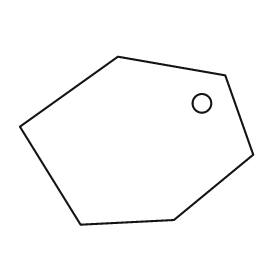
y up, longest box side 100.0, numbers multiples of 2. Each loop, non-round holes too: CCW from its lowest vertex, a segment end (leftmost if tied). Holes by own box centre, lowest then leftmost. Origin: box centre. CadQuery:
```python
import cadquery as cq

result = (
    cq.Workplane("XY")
    .moveTo(-24.0, -36.0)
    .lineTo(16.0, -34.0)
    .lineTo(50.0, -6.0)
    .lineTo(38.0, 28.0)
    .lineTo(-8.0, 36.0)
    .lineTo(-50.0, 6.0)
    .close()
    .moveTo(28.0, 16.0)
    .circle(4.0)
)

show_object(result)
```